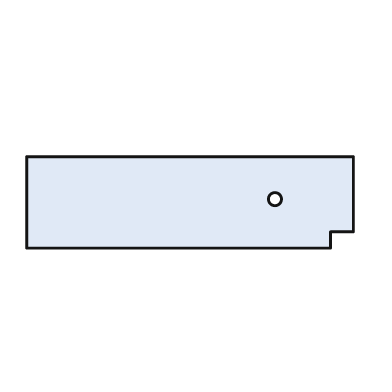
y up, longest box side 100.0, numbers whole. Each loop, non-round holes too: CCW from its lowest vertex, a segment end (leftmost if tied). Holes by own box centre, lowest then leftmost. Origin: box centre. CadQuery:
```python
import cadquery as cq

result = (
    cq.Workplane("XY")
    .moveTo(-50.0, -14.0)
    .lineTo(43.0, -14.0)
    .lineTo(43.0, -9.0)
    .lineTo(50.0, -9.0)
    .lineTo(50.0, 14.0)
    .lineTo(-50.0, 14.0)
    .close()
    .moveTo(26.0, 1.0)
    .circle(2.0)
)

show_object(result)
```